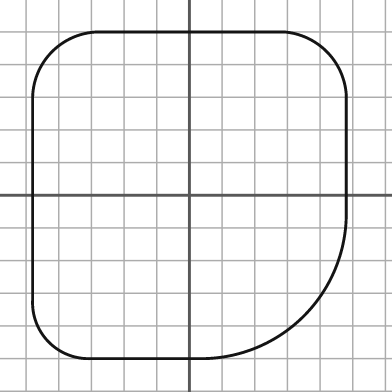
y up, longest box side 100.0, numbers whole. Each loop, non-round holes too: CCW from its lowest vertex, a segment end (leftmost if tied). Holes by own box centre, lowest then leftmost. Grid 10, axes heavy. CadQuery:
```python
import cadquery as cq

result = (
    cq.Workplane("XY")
    .moveTo(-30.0, -50.0)
    .lineTo(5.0, -50.0)
    .threePointArc((35.0, -37.0), (48.0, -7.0))
    .lineTo(48.0, 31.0)
    .threePointArc((42.0, 44.0), (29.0, 50.0))
    .lineTo(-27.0, 50.0)
    .threePointArc((-42.0, 44.0), (-48.0, 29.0))
    .lineTo(-48.0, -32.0)
    .threePointArc((-43.0, -45.0), (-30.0, -50.0))
    .close()
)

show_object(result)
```